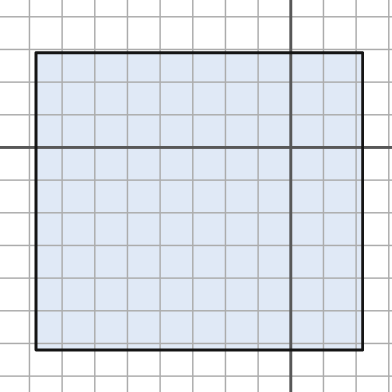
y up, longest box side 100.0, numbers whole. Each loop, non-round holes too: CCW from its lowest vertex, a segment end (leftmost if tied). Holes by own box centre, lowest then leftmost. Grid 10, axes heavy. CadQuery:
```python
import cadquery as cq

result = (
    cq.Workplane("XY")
    .moveTo(-78.0, -62.0)
    .lineTo(22.0, -62.0)
    .lineTo(22.0, 29.0)
    .lineTo(-78.0, 29.0)
    .close()
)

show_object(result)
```